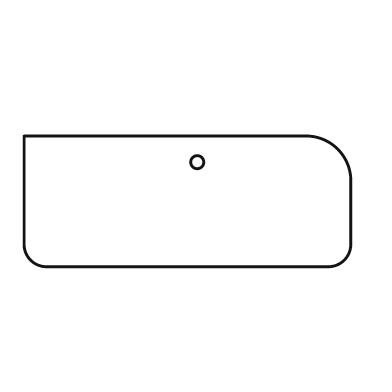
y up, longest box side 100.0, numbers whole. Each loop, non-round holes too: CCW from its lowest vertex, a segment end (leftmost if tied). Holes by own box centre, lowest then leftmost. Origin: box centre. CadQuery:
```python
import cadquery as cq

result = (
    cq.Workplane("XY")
    .moveTo(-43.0, -20.0)
    .lineTo(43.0, -20.0)
    .threePointArc((48.0, -18.0), (50.0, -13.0))
    .lineTo(50.0, 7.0)
    .threePointArc((46.0, 16.0), (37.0, 20.0))
    .lineTo(-50.0, 20.0)
    .lineTo(-50.0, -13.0)
    .threePointArc((-48.0, -18.0), (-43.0, -20.0))
    .close()
    .moveTo(3.0, 12.0)
    .circle(2.0)
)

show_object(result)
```